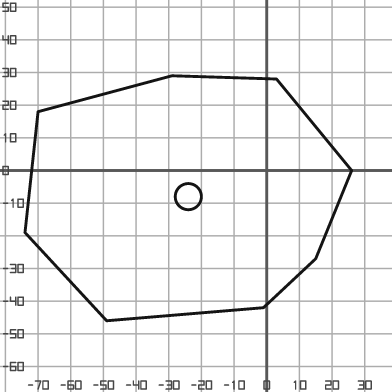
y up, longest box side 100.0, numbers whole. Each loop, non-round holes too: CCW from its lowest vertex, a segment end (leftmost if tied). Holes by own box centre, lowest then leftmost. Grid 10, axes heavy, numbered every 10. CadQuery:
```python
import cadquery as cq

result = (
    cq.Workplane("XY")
    .moveTo(-49.0, -46.0)
    .lineTo(-1.0, -42.0)
    .lineTo(15.0, -27.0)
    .lineTo(26.0, 0.0)
    .lineTo(3.0, 28.0)
    .lineTo(-29.0, 29.0)
    .lineTo(-70.0, 18.0)
    .lineTo(-74.0, -19.0)
    .close()
    .moveTo(-24.0, -8.0)
    .circle(4.0)
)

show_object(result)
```